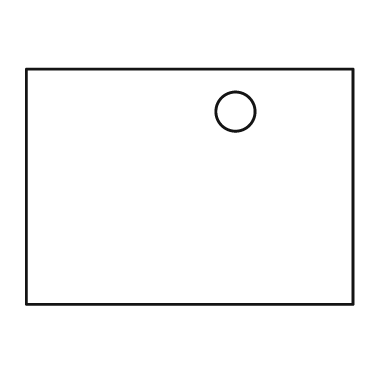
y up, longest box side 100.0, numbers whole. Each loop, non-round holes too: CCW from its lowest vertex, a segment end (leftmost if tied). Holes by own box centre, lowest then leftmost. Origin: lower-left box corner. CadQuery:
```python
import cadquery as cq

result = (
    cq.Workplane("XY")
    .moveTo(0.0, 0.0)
    .lineTo(100.0, 0.0)
    .lineTo(100.0, 72.0)
    .lineTo(0.0, 72.0)
    .close()
    .moveTo(64.0, 59.0)
    .circle(6.0)
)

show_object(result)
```